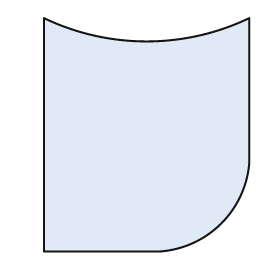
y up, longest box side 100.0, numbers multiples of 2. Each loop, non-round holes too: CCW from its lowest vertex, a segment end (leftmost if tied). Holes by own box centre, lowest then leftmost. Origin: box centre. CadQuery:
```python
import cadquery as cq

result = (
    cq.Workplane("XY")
    .moveTo(-44.0, -50.0)
    .lineTo(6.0, -50.0)
    .threePointArc((32.0, -38.0), (44.0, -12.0))
    .lineTo(44.0, 50.0)
    .threePointArc((0.0, 40.0), (-44.0, 50.0))
    .close()
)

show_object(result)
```